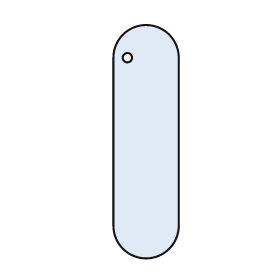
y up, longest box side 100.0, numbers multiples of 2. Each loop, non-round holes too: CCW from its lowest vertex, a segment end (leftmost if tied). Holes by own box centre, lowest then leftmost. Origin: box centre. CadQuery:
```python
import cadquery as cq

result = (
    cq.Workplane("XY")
    .moveTo(-14.0, -36.0)
    .threePointArc((0.0, -50.0), (14.0, -36.0))
    .lineTo(14.0, 36.0)
    .threePointArc((0.0, 50.0), (-14.0, 36.0))
    .close()
    .moveTo(-8.0, 36.0)
    .circle(2.0)
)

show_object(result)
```